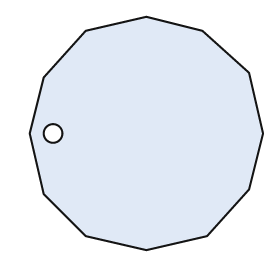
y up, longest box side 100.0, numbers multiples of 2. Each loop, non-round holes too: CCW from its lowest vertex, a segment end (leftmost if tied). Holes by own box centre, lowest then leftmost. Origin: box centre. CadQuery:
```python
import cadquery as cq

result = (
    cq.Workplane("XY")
    .moveTo(0.0, -50.0)
    .lineTo(26.0, -44.0)
    .lineTo(44.0, -24.0)
    .lineTo(50.0, 0.0)
    .lineTo(44.0, 26.0)
    .lineTo(24.0, 44.0)
    .lineTo(0.0, 50.0)
    .lineTo(-26.0, 44.0)
    .lineTo(-44.0, 24.0)
    .lineTo(-50.0, 0.0)
    .lineTo(-44.0, -26.0)
    .lineTo(-26.0, -44.0)
    .close()
    .moveTo(-40.0, 0.0)
    .circle(4.0)
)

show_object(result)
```